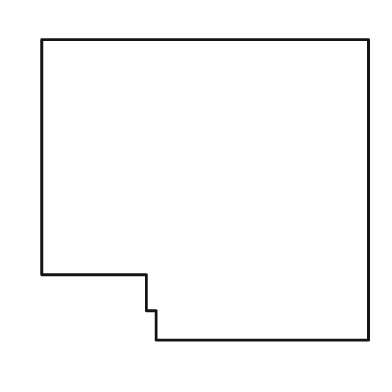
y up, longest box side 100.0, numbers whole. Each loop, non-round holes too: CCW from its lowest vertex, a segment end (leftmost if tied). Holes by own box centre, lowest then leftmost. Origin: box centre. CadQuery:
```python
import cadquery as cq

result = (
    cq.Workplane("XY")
    .moveTo(-15.0, -46.0)
    .lineTo(50.0, -46.0)
    .lineTo(50.0, 46.0)
    .lineTo(-50.0, 46.0)
    .lineTo(-50.0, -26.0)
    .lineTo(-18.0, -26.0)
    .lineTo(-18.0, -37.0)
    .lineTo(-15.0, -37.0)
    .close()
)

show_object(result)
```